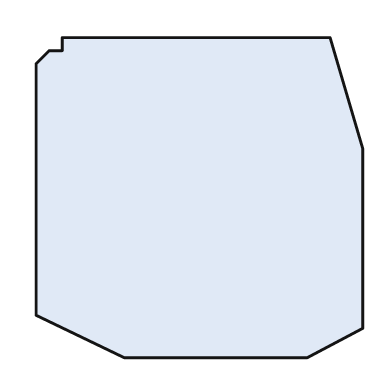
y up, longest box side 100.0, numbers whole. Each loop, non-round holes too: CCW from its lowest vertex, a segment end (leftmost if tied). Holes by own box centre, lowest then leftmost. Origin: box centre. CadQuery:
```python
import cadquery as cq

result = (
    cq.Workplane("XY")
    .moveTo(-23.0, -49.0)
    .lineTo(33.0, -49.0)
    .lineTo(50.0, -40.0)
    .lineTo(50.0, 15.0)
    .lineTo(40.0, 49.0)
    .lineTo(-42.0, 49.0)
    .lineTo(-42.0, 45.0)
    .lineTo(-46.0, 45.0)
    .lineTo(-50.0, 41.0)
    .lineTo(-50.0, -36.0)
    .close()
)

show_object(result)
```